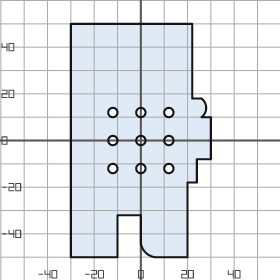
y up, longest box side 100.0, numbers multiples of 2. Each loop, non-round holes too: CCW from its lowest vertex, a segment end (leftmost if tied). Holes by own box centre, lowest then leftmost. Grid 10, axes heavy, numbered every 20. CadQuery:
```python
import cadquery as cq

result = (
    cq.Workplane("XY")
    .moveTo(-30.0, -50.0)
    .lineTo(-10.0, -50.0)
    .lineTo(-10.0, -32.0)
    .lineTo(0.0, -32.0)
    .lineTo(0.0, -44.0)
    .threePointArc((2.0, -48.0), (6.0, -50.0))
    .lineTo(20.0, -50.0)
    .lineTo(20.0, -18.0)
    .lineTo(24.0, -18.0)
    .lineTo(24.0, -8.0)
    .lineTo(30.0, -8.0)
    .lineTo(30.0, 10.0)
    .lineTo(26.0, 10.0)
    .threePointArc((28.0, 14.0), (26.0, 18.0))
    .lineTo(22.0, 18.0)
    .lineTo(22.0, 50.0)
    .lineTo(-30.0, 50.0)
    .close()
    .moveTo(-12.0, -12.0)
    .circle(2.0)
    .moveTo(0.0, -12.0)
    .circle(2.0)
    .moveTo(12.0, -12.0)
    .circle(2.0)
    .moveTo(-12.0, 0.0)
    .circle(2.0)
    .moveTo(0.0, 0.0)
    .circle(2.0)
    .moveTo(12.0, 0.0)
    .circle(2.0)
    .moveTo(-12.0, 12.0)
    .circle(2.0)
    .moveTo(0.0, 12.0)
    .circle(2.0)
    .moveTo(12.0, 12.0)
    .circle(2.0)
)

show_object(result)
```